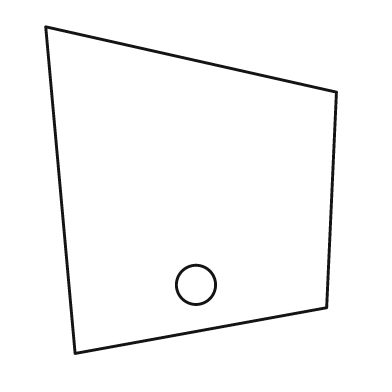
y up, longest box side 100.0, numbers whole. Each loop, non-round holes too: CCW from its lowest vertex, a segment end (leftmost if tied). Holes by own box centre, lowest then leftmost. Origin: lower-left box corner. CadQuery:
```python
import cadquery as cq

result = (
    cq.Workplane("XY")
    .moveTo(9.0, 0.0)
    .lineTo(86.0, 14.0)
    .lineTo(89.0, 80.0)
    .lineTo(0.0, 100.0)
    .close()
    .moveTo(46.0, 21.0)
    .circle(6.0)
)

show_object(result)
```